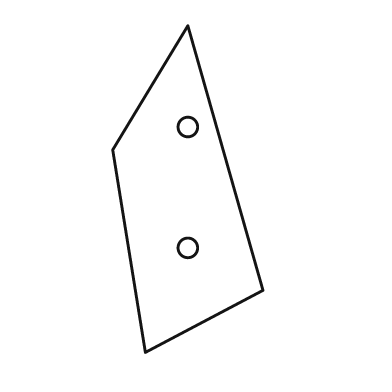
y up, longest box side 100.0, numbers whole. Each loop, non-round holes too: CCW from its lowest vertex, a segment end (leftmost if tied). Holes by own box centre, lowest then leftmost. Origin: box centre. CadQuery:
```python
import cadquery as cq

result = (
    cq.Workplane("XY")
    .moveTo(-13.0, -50.0)
    .lineTo(23.0, -31.0)
    .lineTo(0.0, 50.0)
    .lineTo(-23.0, 12.0)
    .close()
    .moveTo(0.0, -18.0)
    .circle(3.0)
    .moveTo(0.0, 19.0)
    .circle(3.0)
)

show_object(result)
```